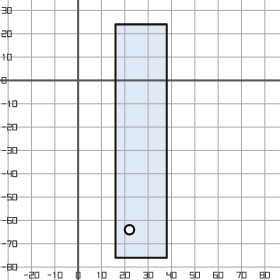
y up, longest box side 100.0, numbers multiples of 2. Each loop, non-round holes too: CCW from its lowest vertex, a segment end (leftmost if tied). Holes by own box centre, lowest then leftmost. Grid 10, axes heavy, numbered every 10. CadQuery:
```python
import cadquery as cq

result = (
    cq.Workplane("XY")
    .moveTo(16.0, -76.0)
    .lineTo(38.0, -76.0)
    .lineTo(38.0, 24.0)
    .lineTo(16.0, 24.0)
    .close()
    .moveTo(22.0, -64.0)
    .circle(2.0)
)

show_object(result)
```